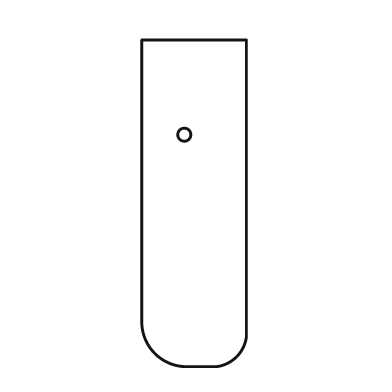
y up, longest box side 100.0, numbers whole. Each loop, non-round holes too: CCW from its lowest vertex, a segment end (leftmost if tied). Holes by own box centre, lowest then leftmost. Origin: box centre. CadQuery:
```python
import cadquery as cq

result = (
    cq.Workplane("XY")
    .moveTo(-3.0, -50.0)
    .lineTo(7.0, -50.0)
    .threePointArc((13.0, -47.0), (16.0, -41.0))
    .lineTo(16.0, 50.0)
    .lineTo(-16.0, 50.0)
    .lineTo(-16.0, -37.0)
    .threePointArc((-12.0, -46.0), (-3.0, -50.0))
    .close()
    .moveTo(-3.0, 21.0)
    .circle(2.0)
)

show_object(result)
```